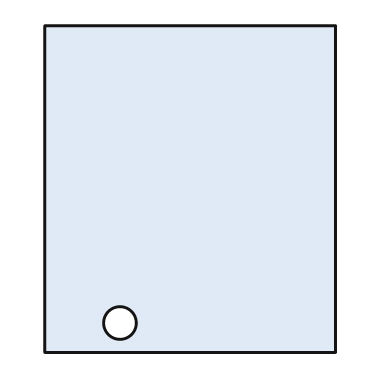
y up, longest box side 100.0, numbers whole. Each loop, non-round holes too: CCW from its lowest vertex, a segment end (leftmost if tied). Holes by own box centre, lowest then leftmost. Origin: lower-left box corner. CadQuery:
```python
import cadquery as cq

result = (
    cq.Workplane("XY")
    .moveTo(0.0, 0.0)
    .lineTo(89.0, 0.0)
    .lineTo(89.0, 100.0)
    .lineTo(0.0, 100.0)
    .close()
    .moveTo(23.0, 9.0)
    .circle(5.0)
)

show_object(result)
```